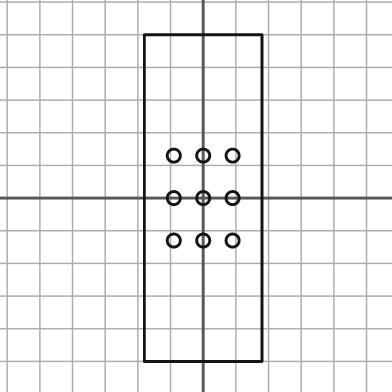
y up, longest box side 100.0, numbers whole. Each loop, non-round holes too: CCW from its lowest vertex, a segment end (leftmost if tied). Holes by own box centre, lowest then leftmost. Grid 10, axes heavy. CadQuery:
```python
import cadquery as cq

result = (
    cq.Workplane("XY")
    .moveTo(-18.0, -50.0)
    .lineTo(18.0, -50.0)
    .lineTo(18.0, 50.0)
    .lineTo(-18.0, 50.0)
    .close()
    .moveTo(-9.0, -13.0)
    .circle(2.0)
    .moveTo(0.0, -13.0)
    .circle(2.0)
    .moveTo(9.0, -13.0)
    .circle(2.0)
    .moveTo(-9.0, 0.0)
    .circle(2.0)
    .moveTo(0.0, 0.0)
    .circle(2.0)
    .moveTo(9.0, 0.0)
    .circle(2.0)
    .moveTo(-9.0, 13.0)
    .circle(2.0)
    .moveTo(0.0, 13.0)
    .circle(2.0)
    .moveTo(9.0, 13.0)
    .circle(2.0)
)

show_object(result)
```